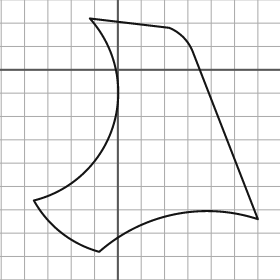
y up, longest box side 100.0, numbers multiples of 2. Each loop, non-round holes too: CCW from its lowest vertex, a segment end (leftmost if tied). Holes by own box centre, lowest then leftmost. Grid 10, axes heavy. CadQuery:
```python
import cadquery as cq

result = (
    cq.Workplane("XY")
    .moveTo(-8.0, -78.0)
    .threePointArc((24.0, -62.0), (60.0, -64.0))
    .lineTo(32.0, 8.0)
    .threePointArc((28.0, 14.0), (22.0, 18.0))
    .lineTo(-12.0, 22.0)
    .threePointArc((-2.0, -24.0), (-36.0, -56.0))
    .threePointArc((-24.0, -70.0), (-8.0, -78.0))
    .close()
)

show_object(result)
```